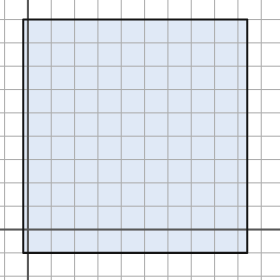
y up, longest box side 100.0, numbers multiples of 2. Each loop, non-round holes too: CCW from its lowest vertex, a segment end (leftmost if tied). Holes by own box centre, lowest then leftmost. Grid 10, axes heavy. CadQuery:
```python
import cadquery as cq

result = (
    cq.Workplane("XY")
    .moveTo(-2.0, -10.0)
    .lineTo(94.0, -10.0)
    .lineTo(94.0, 90.0)
    .lineTo(-2.0, 90.0)
    .close()
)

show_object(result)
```